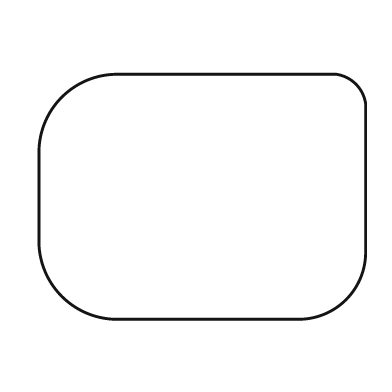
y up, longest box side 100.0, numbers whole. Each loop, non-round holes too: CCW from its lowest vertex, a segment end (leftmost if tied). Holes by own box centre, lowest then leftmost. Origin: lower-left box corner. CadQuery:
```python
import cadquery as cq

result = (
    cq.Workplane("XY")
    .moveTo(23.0, 0.0)
    .lineTo(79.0, 0.0)
    .threePointArc((94.0, 6.0), (100.0, 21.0))
    .lineTo(100.0, 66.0)
    .threePointArc((97.0, 72.0), (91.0, 75.0))
    .lineTo(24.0, 75.0)
    .threePointArc((7.0, 68.0), (0.0, 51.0))
    .lineTo(0.0, 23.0)
    .threePointArc((7.0, 7.0), (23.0, 0.0))
    .close()
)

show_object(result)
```